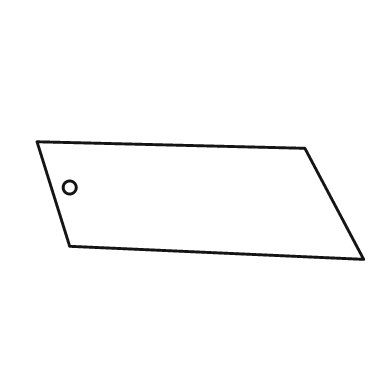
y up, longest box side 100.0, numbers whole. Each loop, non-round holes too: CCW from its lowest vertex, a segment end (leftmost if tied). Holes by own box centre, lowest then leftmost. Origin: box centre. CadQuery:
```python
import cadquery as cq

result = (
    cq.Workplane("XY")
    .moveTo(50.0, -18.0)
    .lineTo(32.0, 16.0)
    .lineTo(-50.0, 18.0)
    .lineTo(-40.0, -14.0)
    .close()
    .moveTo(-40.0, 4.0)
    .circle(2.0)
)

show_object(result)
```